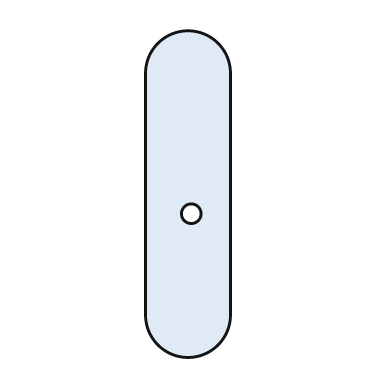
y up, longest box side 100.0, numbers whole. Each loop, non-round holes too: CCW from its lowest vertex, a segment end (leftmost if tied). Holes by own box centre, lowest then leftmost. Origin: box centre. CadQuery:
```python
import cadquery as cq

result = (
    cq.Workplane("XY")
    .moveTo(-13.0, -37.0)
    .threePointArc((0.0, -50.0), (13.0, -37.0))
    .lineTo(13.0, 37.0)
    .threePointArc((0.0, 50.0), (-13.0, 37.0))
    .close()
    .moveTo(1.0, -6.0)
    .circle(3.0)
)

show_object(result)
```